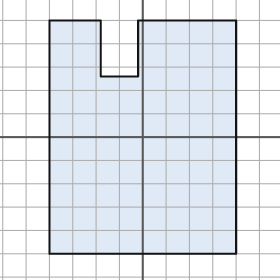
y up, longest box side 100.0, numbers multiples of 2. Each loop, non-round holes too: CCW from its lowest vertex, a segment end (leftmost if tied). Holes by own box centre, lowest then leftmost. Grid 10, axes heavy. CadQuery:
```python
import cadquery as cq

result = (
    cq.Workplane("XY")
    .moveTo(-40.0, -50.0)
    .lineTo(40.0, -50.0)
    .lineTo(40.0, 50.0)
    .lineTo(-2.0, 50.0)
    .lineTo(-2.0, 26.0)
    .lineTo(-18.0, 26.0)
    .lineTo(-18.0, 50.0)
    .lineTo(-40.0, 50.0)
    .close()
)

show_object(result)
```